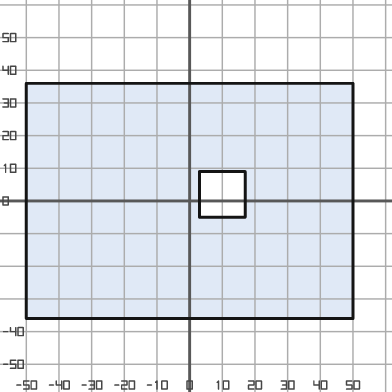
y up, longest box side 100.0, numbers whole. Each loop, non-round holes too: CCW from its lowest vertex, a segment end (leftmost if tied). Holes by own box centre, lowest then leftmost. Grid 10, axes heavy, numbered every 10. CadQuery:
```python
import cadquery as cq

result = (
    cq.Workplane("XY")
    .moveTo(-50.0, -36.0)
    .lineTo(50.0, -36.0)
    .lineTo(50.0, 36.0)
    .lineTo(-50.0, 36.0)
    .close()
    .moveTo(3.0, -5.0)
    .lineTo(17.0, -5.0)
    .lineTo(17.0, 9.0)
    .lineTo(3.0, 9.0)
    .close()
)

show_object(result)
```